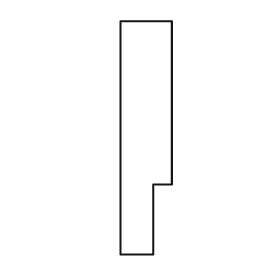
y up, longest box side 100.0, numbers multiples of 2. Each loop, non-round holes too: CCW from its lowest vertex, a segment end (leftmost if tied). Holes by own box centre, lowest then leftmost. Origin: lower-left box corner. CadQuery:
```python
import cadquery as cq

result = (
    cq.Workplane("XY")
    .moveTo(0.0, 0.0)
    .lineTo(14.0, 0.0)
    .lineTo(14.0, 30.0)
    .lineTo(22.0, 30.0)
    .lineTo(22.0, 100.0)
    .lineTo(0.0, 100.0)
    .close()
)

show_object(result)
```